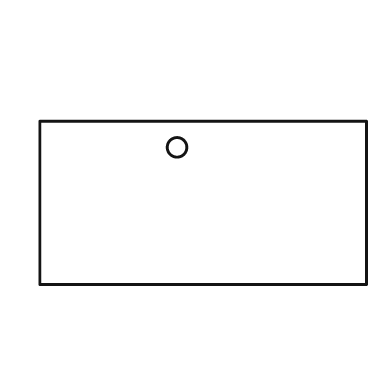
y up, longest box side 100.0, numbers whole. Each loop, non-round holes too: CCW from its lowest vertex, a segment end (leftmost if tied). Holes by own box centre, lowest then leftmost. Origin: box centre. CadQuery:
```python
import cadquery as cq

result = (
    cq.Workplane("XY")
    .moveTo(-50.0, -25.0)
    .lineTo(50.0, -25.0)
    .lineTo(50.0, 25.0)
    .lineTo(-50.0, 25.0)
    .close()
    .moveTo(-8.0, 17.0)
    .circle(3.0)
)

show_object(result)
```